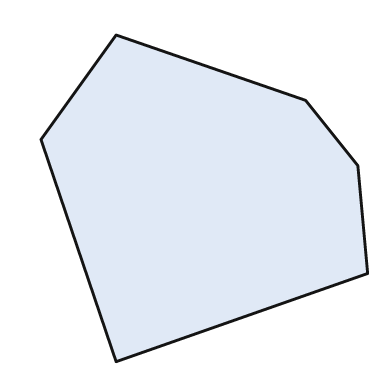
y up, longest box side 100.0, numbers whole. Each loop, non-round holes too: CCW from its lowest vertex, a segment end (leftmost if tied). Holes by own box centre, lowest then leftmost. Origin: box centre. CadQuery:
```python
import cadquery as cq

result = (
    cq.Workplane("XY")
    .moveTo(-27.0, -50.0)
    .lineTo(50.0, -23.0)
    .lineTo(47.0, 10.0)
    .lineTo(31.0, 30.0)
    .lineTo(-27.0, 50.0)
    .lineTo(-50.0, 18.0)
    .close()
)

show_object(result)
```